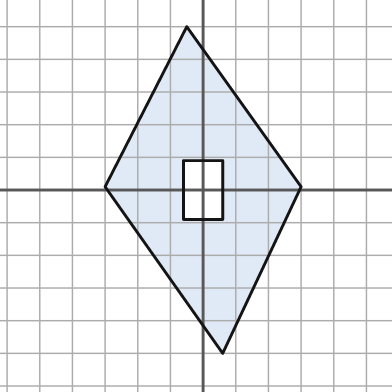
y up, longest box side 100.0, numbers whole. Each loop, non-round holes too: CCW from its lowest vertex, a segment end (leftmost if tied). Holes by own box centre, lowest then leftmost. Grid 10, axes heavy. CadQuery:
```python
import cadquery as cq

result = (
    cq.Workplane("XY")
    .moveTo(6.0, -50.0)
    .lineTo(30.0, 1.0)
    .lineTo(-5.0, 50.0)
    .lineTo(-30.0, 1.0)
    .close()
    .moveTo(-6.0, -9.0)
    .lineTo(6.0, -9.0)
    .lineTo(6.0, 9.0)
    .lineTo(-6.0, 9.0)
    .close()
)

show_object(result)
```